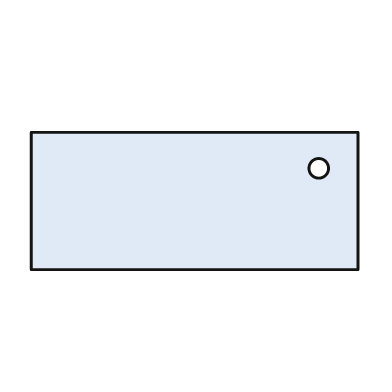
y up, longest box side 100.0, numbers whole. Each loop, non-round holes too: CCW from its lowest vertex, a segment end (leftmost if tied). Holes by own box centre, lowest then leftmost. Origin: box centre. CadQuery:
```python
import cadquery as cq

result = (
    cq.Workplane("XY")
    .moveTo(-50.0, -21.0)
    .lineTo(50.0, -21.0)
    .lineTo(50.0, 21.0)
    .lineTo(-50.0, 21.0)
    .close()
    .moveTo(38.0, 10.0)
    .circle(3.0)
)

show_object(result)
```